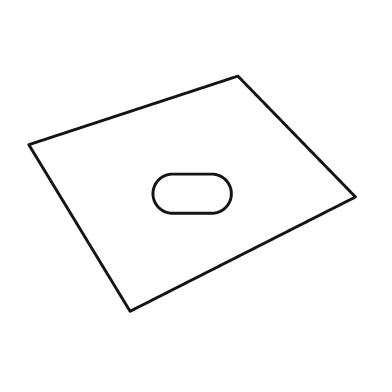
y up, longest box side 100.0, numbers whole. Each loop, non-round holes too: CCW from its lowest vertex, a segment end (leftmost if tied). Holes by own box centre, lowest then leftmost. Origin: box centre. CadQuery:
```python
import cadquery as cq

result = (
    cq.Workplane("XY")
    .moveTo(-19.0, -36.0)
    .lineTo(50.0, -1.0)
    .lineTo(14.0, 36.0)
    .lineTo(-50.0, 15.0)
    .close()
    .moveTo(-6.0, -6.0)
    .lineTo(6.0, -6.0)
    .threePointArc((12.0, 0.0), (6.0, 6.0))
    .lineTo(-6.0, 6.0)
    .threePointArc((-12.0, 0.0), (-6.0, -6.0))
    .close()
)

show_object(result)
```